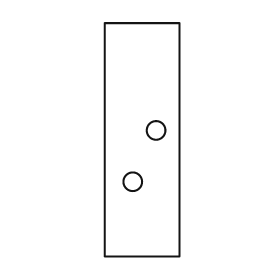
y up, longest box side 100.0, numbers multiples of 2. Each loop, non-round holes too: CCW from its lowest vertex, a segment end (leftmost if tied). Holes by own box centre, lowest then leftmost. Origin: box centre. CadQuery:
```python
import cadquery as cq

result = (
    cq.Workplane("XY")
    .moveTo(-16.0, -50.0)
    .lineTo(16.0, -50.0)
    .lineTo(16.0, 50.0)
    .lineTo(-16.0, 50.0)
    .close()
    .moveTo(-4.0, -18.0)
    .circle(4.0)
    .moveTo(6.0, 4.0)
    .circle(4.0)
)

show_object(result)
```